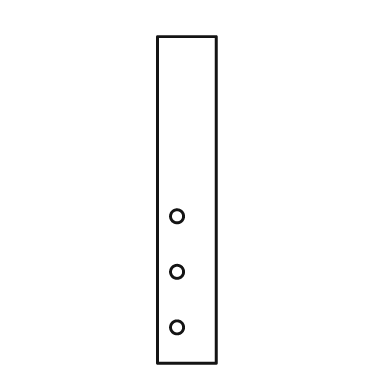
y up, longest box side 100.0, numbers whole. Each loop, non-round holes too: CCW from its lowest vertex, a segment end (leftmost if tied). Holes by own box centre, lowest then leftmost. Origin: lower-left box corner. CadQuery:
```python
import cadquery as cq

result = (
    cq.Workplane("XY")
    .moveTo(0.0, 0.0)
    .lineTo(18.0, 0.0)
    .lineTo(18.0, 100.0)
    .lineTo(0.0, 100.0)
    .close()
    .moveTo(6.0, 11.0)
    .circle(2.0)
    .moveTo(6.0, 28.0)
    .circle(2.0)
    .moveTo(6.0, 45.0)
    .circle(2.0)
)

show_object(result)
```